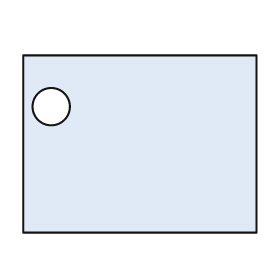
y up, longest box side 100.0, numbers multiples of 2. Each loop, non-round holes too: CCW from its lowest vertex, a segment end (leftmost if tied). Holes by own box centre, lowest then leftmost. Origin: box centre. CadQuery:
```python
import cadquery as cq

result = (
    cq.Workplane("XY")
    .moveTo(-50.0, -38.0)
    .lineTo(50.0, -38.0)
    .lineTo(50.0, 38.0)
    .lineTo(-50.0, 38.0)
    .close()
    .moveTo(-38.0, 16.0)
    .circle(8.0)
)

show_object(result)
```